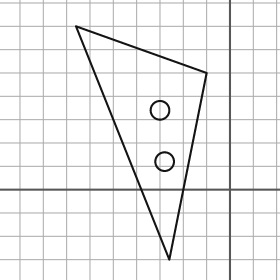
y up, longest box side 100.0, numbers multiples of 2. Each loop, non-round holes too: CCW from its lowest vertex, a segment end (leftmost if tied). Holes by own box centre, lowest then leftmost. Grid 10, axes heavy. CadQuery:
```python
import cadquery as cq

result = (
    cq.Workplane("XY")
    .moveTo(-26.0, -30.0)
    .lineTo(-10.0, 50.0)
    .lineTo(-66.0, 70.0)
    .close()
    .moveTo(-28.0, 12.0)
    .circle(4.0)
    .moveTo(-30.0, 34.0)
    .circle(4.0)
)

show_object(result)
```